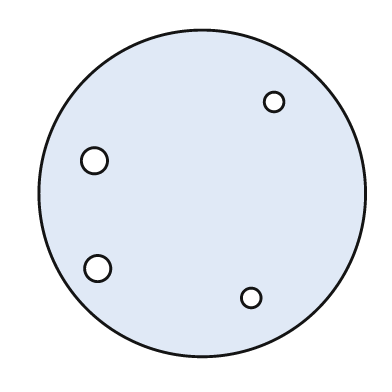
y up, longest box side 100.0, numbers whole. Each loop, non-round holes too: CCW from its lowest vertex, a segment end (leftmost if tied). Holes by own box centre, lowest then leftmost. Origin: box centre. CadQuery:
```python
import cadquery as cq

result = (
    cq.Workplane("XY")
    .moveTo(0.0, 0.0)
    .circle(50.0)
    .moveTo(15.0, -32.0)
    .circle(3.0)
    .moveTo(-32.0, -23.0)
    .circle(4.0)
    .moveTo(-33.0, 10.0)
    .circle(4.0)
    .moveTo(22.0, 28.0)
    .circle(3.0)
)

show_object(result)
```